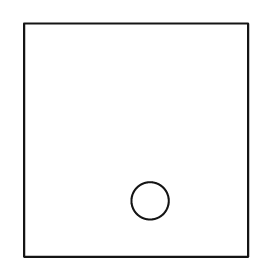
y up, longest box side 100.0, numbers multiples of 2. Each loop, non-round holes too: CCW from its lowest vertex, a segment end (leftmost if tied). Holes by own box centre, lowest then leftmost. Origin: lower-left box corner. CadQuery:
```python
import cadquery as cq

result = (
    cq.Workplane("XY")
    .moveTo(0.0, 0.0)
    .lineTo(96.0, 0.0)
    .lineTo(96.0, 100.0)
    .lineTo(0.0, 100.0)
    .close()
    .moveTo(54.0, 24.0)
    .circle(8.0)
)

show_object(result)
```